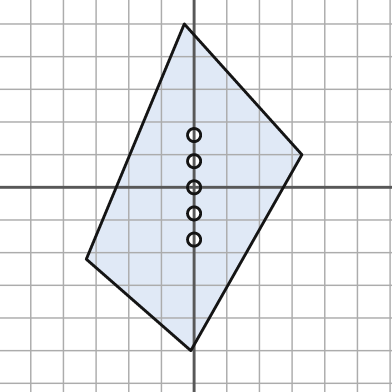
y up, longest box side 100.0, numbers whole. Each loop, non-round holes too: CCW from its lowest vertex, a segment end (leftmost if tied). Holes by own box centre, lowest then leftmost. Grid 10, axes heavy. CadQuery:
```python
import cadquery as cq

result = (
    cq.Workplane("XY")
    .moveTo(-1.0, -50.0)
    .lineTo(33.0, 10.0)
    .lineTo(-3.0, 50.0)
    .lineTo(-33.0, -22.0)
    .close()
    .moveTo(0.0, -16.0)
    .circle(2.0)
    .moveTo(0.0, -8.0)
    .circle(2.0)
    .moveTo(0.0, 0.0)
    .circle(2.0)
    .moveTo(0.0, 8.0)
    .circle(2.0)
    .moveTo(0.0, 16.0)
    .circle(2.0)
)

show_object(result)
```